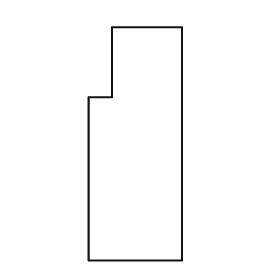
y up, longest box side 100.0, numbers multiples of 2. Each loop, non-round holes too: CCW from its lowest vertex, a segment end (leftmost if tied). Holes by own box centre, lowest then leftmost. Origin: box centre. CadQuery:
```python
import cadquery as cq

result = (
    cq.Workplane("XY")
    .moveTo(-20.0, -50.0)
    .lineTo(20.0, -50.0)
    .lineTo(20.0, 50.0)
    .lineTo(-10.0, 50.0)
    .lineTo(-10.0, 20.0)
    .lineTo(-20.0, 20.0)
    .close()
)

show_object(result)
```